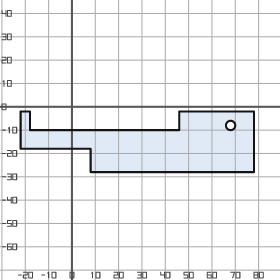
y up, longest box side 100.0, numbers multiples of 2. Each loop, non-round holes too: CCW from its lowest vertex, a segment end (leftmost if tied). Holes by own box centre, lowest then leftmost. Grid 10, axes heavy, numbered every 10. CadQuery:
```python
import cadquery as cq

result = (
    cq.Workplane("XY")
    .moveTo(8.0, -28.0)
    .lineTo(78.0, -28.0)
    .lineTo(78.0, -2.0)
    .lineTo(46.0, -2.0)
    .lineTo(46.0, -10.0)
    .lineTo(-18.0, -10.0)
    .lineTo(-18.0, -2.0)
    .lineTo(-22.0, -2.0)
    .lineTo(-22.0, -18.0)
    .lineTo(8.0, -18.0)
    .close()
    .moveTo(68.0, -8.0)
    .circle(2.0)
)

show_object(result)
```